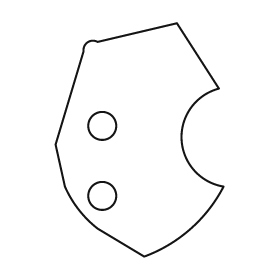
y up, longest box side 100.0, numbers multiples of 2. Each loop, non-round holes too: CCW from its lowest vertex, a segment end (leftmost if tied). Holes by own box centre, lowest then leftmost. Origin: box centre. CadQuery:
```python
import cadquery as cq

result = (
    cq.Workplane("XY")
    .moveTo(2.0, -50.0)
    .threePointArc((22.0, -38.0), (36.0, -20.0))
    .threePointArc((18.0, 0.0), (34.0, 22.0))
    .lineTo(16.0, 50.0)
    .lineTo(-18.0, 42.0)
    .threePointArc((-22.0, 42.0), (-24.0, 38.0))
    .lineTo(-36.0, -2.0)
    .lineTo(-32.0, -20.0)
    .threePointArc((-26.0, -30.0), (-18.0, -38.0))
    .close()
    .moveTo(-16.0, -24.0)
    .circle(6.0)
    .moveTo(-16.0, 6.0)
    .circle(6.0)
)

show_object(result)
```